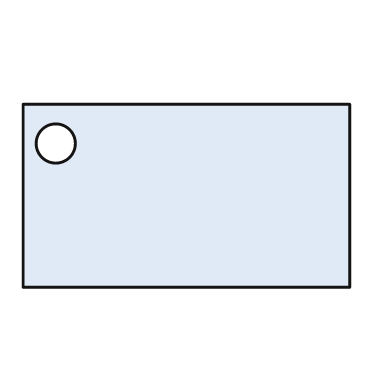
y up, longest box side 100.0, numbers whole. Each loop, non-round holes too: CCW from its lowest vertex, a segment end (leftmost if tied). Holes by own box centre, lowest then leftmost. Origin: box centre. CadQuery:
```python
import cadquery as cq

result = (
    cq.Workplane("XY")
    .moveTo(-50.0, -28.0)
    .lineTo(50.0, -28.0)
    .lineTo(50.0, 28.0)
    .lineTo(-50.0, 28.0)
    .close()
    .moveTo(-40.0, 16.0)
    .circle(6.0)
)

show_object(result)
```